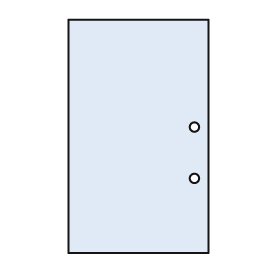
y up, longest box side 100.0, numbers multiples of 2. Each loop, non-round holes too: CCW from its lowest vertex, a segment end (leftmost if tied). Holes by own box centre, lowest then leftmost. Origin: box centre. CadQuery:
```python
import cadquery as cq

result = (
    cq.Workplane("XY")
    .moveTo(-30.0, -50.0)
    .lineTo(30.0, -50.0)
    .lineTo(30.0, 50.0)
    .lineTo(-30.0, 50.0)
    .close()
    .moveTo(24.0, -18.0)
    .circle(2.0)
    .moveTo(24.0, 4.0)
    .circle(2.0)
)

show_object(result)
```